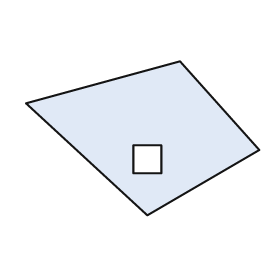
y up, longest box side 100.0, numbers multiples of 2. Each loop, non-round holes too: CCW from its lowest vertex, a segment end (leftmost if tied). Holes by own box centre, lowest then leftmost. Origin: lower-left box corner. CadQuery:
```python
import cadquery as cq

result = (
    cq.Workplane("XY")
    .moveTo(52.0, 0.0)
    .lineTo(100.0, 28.0)
    .lineTo(66.0, 66.0)
    .lineTo(0.0, 48.0)
    .close()
    .moveTo(46.0, 18.0)
    .lineTo(58.0, 18.0)
    .lineTo(58.0, 30.0)
    .lineTo(46.0, 30.0)
    .close()
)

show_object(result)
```